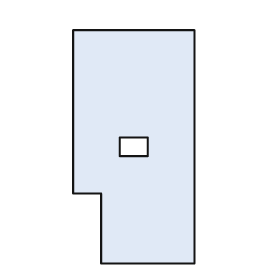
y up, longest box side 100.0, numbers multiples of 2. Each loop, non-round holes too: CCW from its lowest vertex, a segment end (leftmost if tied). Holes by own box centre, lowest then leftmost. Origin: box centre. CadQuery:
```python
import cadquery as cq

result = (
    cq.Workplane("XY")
    .moveTo(-14.0, -50.0)
    .lineTo(26.0, -50.0)
    .lineTo(26.0, 50.0)
    .lineTo(-26.0, 50.0)
    .lineTo(-26.0, -20.0)
    .lineTo(-14.0, -20.0)
    .close()
    .moveTo(-6.0, -4.0)
    .lineTo(6.0, -4.0)
    .lineTo(6.0, 4.0)
    .lineTo(-6.0, 4.0)
    .close()
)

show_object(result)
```